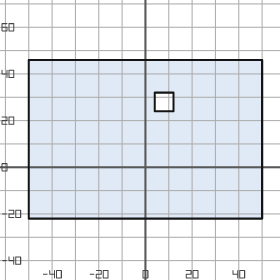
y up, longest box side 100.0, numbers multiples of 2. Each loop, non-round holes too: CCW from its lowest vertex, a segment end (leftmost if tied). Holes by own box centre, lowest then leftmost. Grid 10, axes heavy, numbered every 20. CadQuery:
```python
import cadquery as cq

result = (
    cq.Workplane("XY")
    .moveTo(-50.0, -22.0)
    .lineTo(50.0, -22.0)
    .lineTo(50.0, 46.0)
    .lineTo(-50.0, 46.0)
    .close()
    .moveTo(4.0, 24.0)
    .lineTo(12.0, 24.0)
    .lineTo(12.0, 32.0)
    .lineTo(4.0, 32.0)
    .close()
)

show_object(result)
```